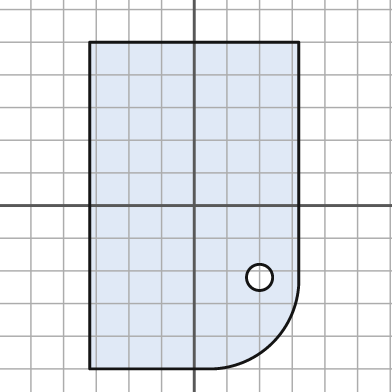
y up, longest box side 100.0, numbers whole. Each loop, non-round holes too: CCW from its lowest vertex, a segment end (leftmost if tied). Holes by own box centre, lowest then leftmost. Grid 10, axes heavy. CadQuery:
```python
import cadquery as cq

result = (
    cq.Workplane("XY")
    .moveTo(-32.0, -50.0)
    .lineTo(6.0, -50.0)
    .threePointArc((24.0, -42.0), (32.0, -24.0))
    .lineTo(32.0, 50.0)
    .lineTo(-32.0, 50.0)
    .close()
    .moveTo(20.0, -22.0)
    .circle(4.0)
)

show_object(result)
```